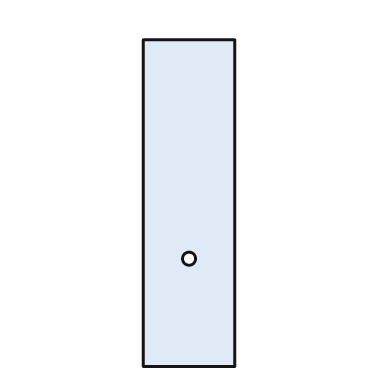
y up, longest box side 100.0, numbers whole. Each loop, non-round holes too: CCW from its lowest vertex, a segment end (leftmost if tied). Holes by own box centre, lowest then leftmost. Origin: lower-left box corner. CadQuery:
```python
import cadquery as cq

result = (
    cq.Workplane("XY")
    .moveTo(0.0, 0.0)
    .lineTo(28.0, 0.0)
    .lineTo(28.0, 100.0)
    .lineTo(0.0, 100.0)
    .close()
    .moveTo(14.0, 33.0)
    .circle(2.0)
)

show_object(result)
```